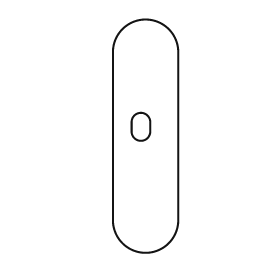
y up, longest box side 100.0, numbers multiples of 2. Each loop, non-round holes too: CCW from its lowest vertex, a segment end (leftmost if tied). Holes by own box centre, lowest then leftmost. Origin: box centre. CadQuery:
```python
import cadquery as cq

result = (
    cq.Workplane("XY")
    .moveTo(-14.0, -36.0)
    .threePointArc((0.0, -50.0), (14.0, -36.0))
    .lineTo(14.0, 36.0)
    .threePointArc((0.0, 50.0), (-14.0, 36.0))
    .close()
    .moveTo(-6.0, 2.0)
    .threePointArc((-2.0, -2.0), (2.0, 2.0))
    .lineTo(2.0, 6.0)
    .threePointArc((-2.0, 10.0), (-6.0, 6.0))
    .close()
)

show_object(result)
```